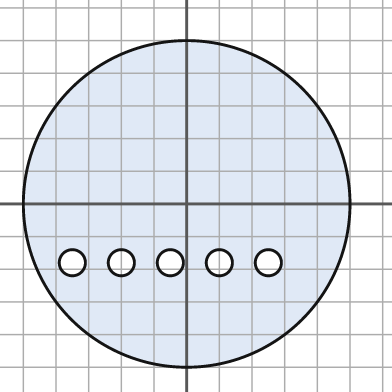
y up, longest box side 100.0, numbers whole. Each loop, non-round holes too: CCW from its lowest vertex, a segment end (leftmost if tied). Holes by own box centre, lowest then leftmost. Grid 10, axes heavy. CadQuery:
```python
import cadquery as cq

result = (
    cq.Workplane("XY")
    .moveTo(0.0, 0.0)
    .circle(50.0)
    .moveTo(-35.0, -18.0)
    .circle(4.0)
    .moveTo(-20.0, -18.0)
    .circle(4.0)
    .moveTo(-5.0, -18.0)
    .circle(4.0)
    .moveTo(10.0, -18.0)
    .circle(4.0)
    .moveTo(25.0, -18.0)
    .circle(4.0)
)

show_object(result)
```